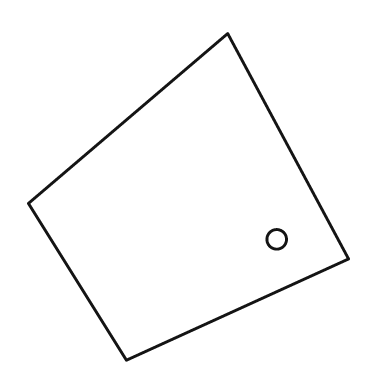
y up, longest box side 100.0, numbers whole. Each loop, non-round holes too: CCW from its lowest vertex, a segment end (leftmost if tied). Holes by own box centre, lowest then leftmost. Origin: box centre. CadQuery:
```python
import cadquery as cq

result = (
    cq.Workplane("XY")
    .moveTo(-19.0, -50.0)
    .lineTo(49.0, -19.0)
    .lineTo(12.0, 50.0)
    .lineTo(-49.0, -2.0)
    .close()
    .moveTo(27.0, -13.0)
    .circle(3.0)
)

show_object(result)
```